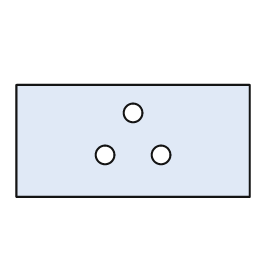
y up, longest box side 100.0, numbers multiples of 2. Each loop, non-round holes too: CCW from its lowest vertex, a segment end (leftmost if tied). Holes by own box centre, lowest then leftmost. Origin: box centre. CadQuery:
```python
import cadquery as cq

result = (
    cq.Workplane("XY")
    .moveTo(-50.0, -24.0)
    .lineTo(50.0, -24.0)
    .lineTo(50.0, 24.0)
    .lineTo(-50.0, 24.0)
    .close()
    .moveTo(-12.0, -6.0)
    .circle(4.0)
    .moveTo(12.0, -6.0)
    .circle(4.0)
    .moveTo(0.0, 12.0)
    .circle(4.0)
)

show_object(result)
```